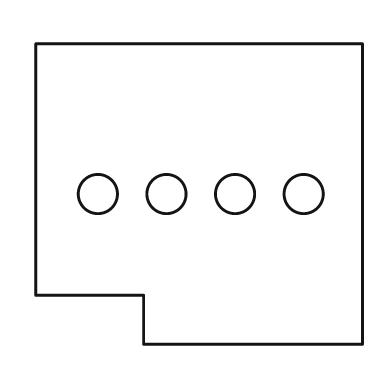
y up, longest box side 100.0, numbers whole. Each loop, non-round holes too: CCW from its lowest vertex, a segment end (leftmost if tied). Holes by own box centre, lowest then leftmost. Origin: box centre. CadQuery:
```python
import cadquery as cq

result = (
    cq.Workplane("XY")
    .moveTo(-17.0, -46.0)
    .lineTo(50.0, -46.0)
    .lineTo(50.0, 46.0)
    .lineTo(-50.0, 46.0)
    .lineTo(-50.0, -31.0)
    .lineTo(-17.0, -31.0)
    .close()
    .moveTo(-31.0, 0.0)
    .circle(6.0)
    .moveTo(-10.0, 0.0)
    .circle(6.0)
    .moveTo(11.0, 0.0)
    .circle(6.0)
    .moveTo(32.0, 0.0)
    .circle(6.0)
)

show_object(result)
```